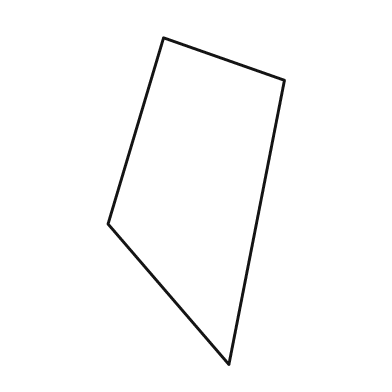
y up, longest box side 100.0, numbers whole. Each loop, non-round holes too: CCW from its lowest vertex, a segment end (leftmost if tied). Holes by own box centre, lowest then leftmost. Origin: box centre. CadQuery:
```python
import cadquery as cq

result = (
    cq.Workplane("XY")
    .moveTo(10.0, -50.0)
    .lineTo(27.0, 37.0)
    .lineTo(-10.0, 50.0)
    .lineTo(-27.0, -7.0)
    .close()
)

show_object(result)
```